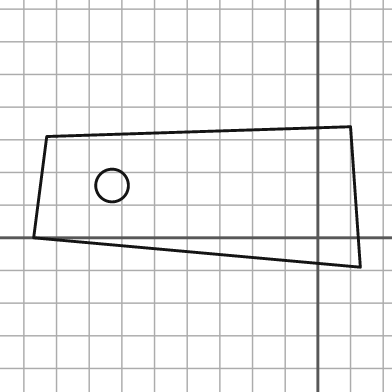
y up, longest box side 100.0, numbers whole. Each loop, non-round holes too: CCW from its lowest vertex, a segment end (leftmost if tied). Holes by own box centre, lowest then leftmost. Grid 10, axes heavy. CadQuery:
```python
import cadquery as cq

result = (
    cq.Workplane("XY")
    .moveTo(13.0, -9.0)
    .lineTo(10.0, 34.0)
    .lineTo(-83.0, 31.0)
    .lineTo(-87.0, 0.0)
    .close()
    .moveTo(-63.0, 16.0)
    .circle(5.0)
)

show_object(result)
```